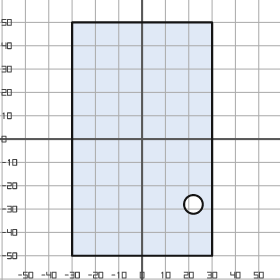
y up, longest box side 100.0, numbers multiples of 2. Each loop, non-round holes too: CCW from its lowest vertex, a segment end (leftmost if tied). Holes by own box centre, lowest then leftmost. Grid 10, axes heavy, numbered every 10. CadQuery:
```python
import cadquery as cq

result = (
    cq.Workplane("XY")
    .moveTo(-30.0, -50.0)
    .lineTo(30.0, -50.0)
    .lineTo(30.0, 50.0)
    .lineTo(-30.0, 50.0)
    .close()
    .moveTo(22.0, -28.0)
    .circle(4.0)
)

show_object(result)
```